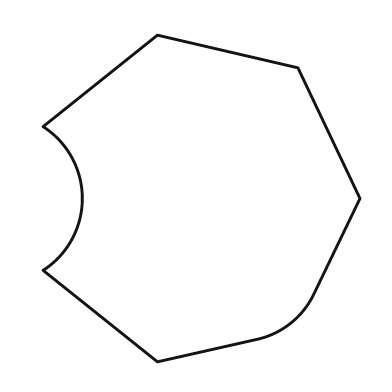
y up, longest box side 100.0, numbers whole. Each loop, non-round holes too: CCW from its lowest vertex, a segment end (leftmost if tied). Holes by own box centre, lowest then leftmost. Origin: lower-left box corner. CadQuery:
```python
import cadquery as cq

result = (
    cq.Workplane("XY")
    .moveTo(35.0, 0.0)
    .lineTo(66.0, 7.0)
    .threePointArc((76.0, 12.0), (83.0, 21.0))
    .lineTo(97.0, 50.0)
    .lineTo(78.0, 90.0)
    .lineTo(35.0, 100.0)
    .lineTo(0.0, 72.0)
    .threePointArc((12.0, 50.0), (0.0, 28.0))
    .close()
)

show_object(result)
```